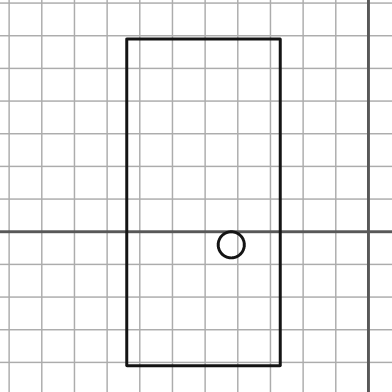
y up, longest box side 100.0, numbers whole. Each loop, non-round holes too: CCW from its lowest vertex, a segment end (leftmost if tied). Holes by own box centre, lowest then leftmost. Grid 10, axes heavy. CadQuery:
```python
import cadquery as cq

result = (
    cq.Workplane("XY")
    .moveTo(-74.0, -41.0)
    .lineTo(-27.0, -41.0)
    .lineTo(-27.0, 59.0)
    .lineTo(-74.0, 59.0)
    .close()
    .moveTo(-42.0, -4.0)
    .circle(4.0)
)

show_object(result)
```